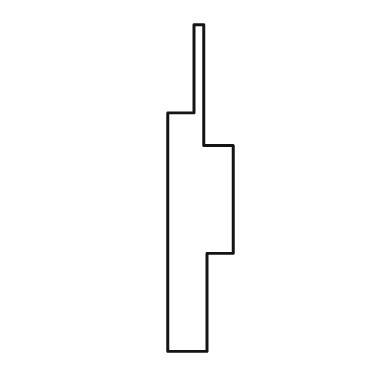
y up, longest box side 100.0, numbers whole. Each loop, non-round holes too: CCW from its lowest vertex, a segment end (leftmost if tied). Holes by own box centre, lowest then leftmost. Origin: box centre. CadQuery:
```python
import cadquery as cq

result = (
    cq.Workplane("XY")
    .moveTo(-10.0, -50.0)
    .lineTo(2.0, -50.0)
    .lineTo(2.0, -20.0)
    .lineTo(10.0, -20.0)
    .lineTo(10.0, 13.0)
    .lineTo(1.0, 13.0)
    .lineTo(1.0, 50.0)
    .lineTo(-2.0, 50.0)
    .lineTo(-2.0, 23.0)
    .lineTo(-10.0, 23.0)
    .close()
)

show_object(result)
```